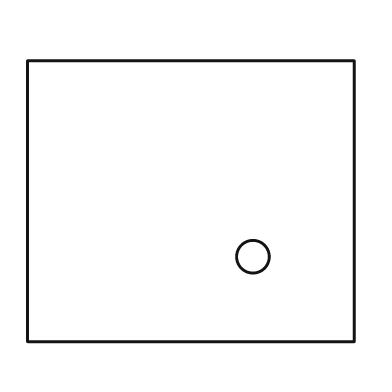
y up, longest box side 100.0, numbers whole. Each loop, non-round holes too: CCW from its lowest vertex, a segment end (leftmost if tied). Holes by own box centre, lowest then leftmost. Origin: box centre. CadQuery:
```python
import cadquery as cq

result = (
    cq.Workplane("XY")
    .moveTo(-50.0, -43.0)
    .lineTo(50.0, -43.0)
    .lineTo(50.0, 43.0)
    .lineTo(-50.0, 43.0)
    .close()
    .moveTo(19.0, -17.0)
    .circle(5.0)
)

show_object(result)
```